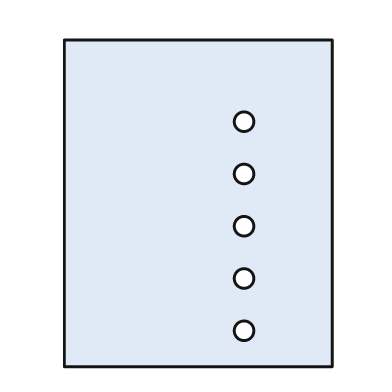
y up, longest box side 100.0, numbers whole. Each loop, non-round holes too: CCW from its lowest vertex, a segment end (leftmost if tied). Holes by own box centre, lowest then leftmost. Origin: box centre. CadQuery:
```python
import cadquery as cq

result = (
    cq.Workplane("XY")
    .moveTo(-41.0, -50.0)
    .lineTo(41.0, -50.0)
    .lineTo(41.0, 50.0)
    .lineTo(-41.0, 50.0)
    .close()
    .moveTo(14.0, -39.0)
    .circle(3.0)
    .moveTo(14.0, -23.0)
    .circle(3.0)
    .moveTo(14.0, -7.0)
    .circle(3.0)
    .moveTo(14.0, 9.0)
    .circle(3.0)
    .moveTo(14.0, 25.0)
    .circle(3.0)
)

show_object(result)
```